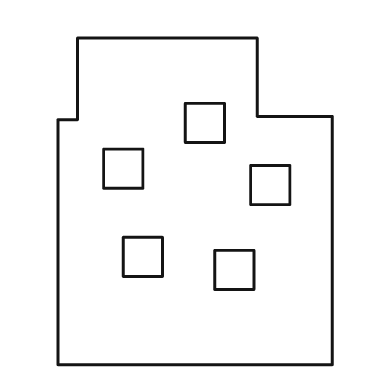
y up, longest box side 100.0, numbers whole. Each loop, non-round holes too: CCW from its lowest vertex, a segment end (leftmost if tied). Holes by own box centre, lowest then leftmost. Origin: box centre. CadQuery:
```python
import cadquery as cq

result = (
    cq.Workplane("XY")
    .moveTo(-42.0, -50.0)
    .lineTo(42.0, -50.0)
    .lineTo(42.0, 26.0)
    .lineTo(19.0, 26.0)
    .lineTo(19.0, 50.0)
    .lineTo(-36.0, 50.0)
    .lineTo(-36.0, 25.0)
    .lineTo(-42.0, 25.0)
    .close()
    .moveTo(6.0, -27.0)
    .lineTo(18.0, -27.0)
    .lineTo(18.0, -15.0)
    .lineTo(6.0, -15.0)
    .close()
    .moveTo(-22.0, -23.0)
    .lineTo(-10.0, -23.0)
    .lineTo(-10.0, -11.0)
    .lineTo(-22.0, -11.0)
    .close()
    .moveTo(17.0, -1.0)
    .lineTo(29.0, -1.0)
    .lineTo(29.0, 11.0)
    .lineTo(17.0, 11.0)
    .close()
    .moveTo(-28.0, 4.0)
    .lineTo(-16.0, 4.0)
    .lineTo(-16.0, 16.0)
    .lineTo(-28.0, 16.0)
    .close()
    .moveTo(-3.0, 18.0)
    .lineTo(9.0, 18.0)
    .lineTo(9.0, 30.0)
    .lineTo(-3.0, 30.0)
    .close()
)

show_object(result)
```